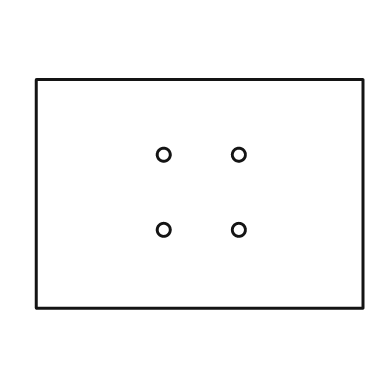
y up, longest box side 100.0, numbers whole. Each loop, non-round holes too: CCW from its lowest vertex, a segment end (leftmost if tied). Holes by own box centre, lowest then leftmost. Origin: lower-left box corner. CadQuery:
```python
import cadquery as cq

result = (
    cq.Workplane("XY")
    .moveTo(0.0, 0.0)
    .lineTo(100.0, 0.0)
    .lineTo(100.0, 70.0)
    .lineTo(0.0, 70.0)
    .close()
    .moveTo(39.0, 24.0)
    .circle(2.0)
    .moveTo(62.0, 24.0)
    .circle(2.0)
    .moveTo(39.0, 47.0)
    .circle(2.0)
    .moveTo(62.0, 47.0)
    .circle(2.0)
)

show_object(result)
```